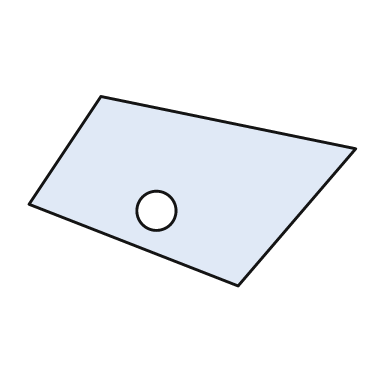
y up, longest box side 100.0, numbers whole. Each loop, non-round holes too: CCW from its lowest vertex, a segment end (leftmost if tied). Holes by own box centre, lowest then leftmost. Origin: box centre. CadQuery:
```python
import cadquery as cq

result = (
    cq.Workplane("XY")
    .moveTo(14.0, -29.0)
    .lineTo(50.0, 13.0)
    .lineTo(-28.0, 29.0)
    .lineTo(-50.0, -4.0)
    .close()
    .moveTo(-11.0, -6.0)
    .circle(6.0)
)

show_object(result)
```